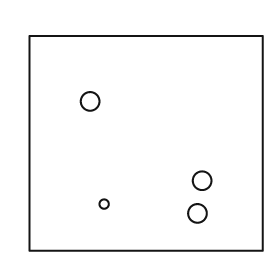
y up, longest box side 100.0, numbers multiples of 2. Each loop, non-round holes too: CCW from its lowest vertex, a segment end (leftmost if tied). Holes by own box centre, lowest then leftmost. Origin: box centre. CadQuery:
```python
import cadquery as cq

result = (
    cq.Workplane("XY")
    .moveTo(-50.0, -46.0)
    .lineTo(50.0, -46.0)
    .lineTo(50.0, 46.0)
    .lineTo(-50.0, 46.0)
    .close()
    .moveTo(22.0, -30.0)
    .circle(4.0)
    .moveTo(-18.0, -26.0)
    .circle(2.0)
    .moveTo(24.0, -16.0)
    .circle(4.0)
    .moveTo(-24.0, 18.0)
    .circle(4.0)
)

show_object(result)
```